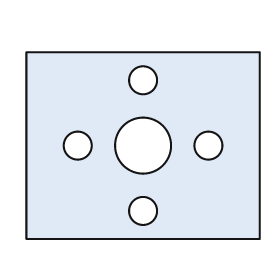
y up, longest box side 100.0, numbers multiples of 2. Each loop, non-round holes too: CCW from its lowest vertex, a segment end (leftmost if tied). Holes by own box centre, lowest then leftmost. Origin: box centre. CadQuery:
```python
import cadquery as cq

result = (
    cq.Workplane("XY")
    .moveTo(-50.0, -40.0)
    .lineTo(50.0, -40.0)
    .lineTo(50.0, 40.0)
    .lineTo(-50.0, 40.0)
    .close()
    .moveTo(0.0, -28.0)
    .circle(6.0)
    .moveTo(-28.0, 0.0)
    .circle(6.0)
    .moveTo(0.0, 0.0)
    .circle(12.0)
    .moveTo(28.0, 0.0)
    .circle(6.0)
    .moveTo(0.0, 28.0)
    .circle(6.0)
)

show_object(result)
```